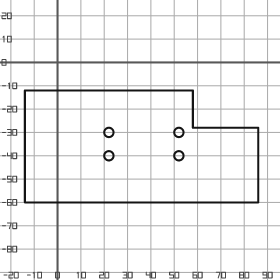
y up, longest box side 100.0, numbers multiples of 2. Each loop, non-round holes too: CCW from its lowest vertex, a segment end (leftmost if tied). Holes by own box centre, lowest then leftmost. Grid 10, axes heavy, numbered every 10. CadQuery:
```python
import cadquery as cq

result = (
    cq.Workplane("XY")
    .moveTo(-14.0, -60.0)
    .lineTo(86.0, -60.0)
    .lineTo(86.0, -28.0)
    .lineTo(58.0, -28.0)
    .lineTo(58.0, -12.0)
    .lineTo(-14.0, -12.0)
    .close()
    .moveTo(22.0, -40.0)
    .circle(2.0)
    .moveTo(52.0, -40.0)
    .circle(2.0)
    .moveTo(22.0, -30.0)
    .circle(2.0)
    .moveTo(52.0, -30.0)
    .circle(2.0)
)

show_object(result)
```